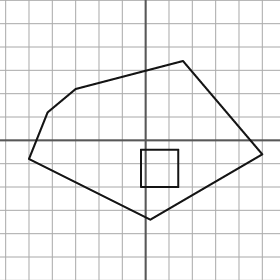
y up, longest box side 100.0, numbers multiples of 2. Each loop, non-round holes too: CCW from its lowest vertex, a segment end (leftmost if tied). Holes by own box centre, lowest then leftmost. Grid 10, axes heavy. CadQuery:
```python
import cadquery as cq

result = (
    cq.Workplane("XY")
    .moveTo(2.0, -34.0)
    .lineTo(50.0, -6.0)
    .lineTo(16.0, 34.0)
    .lineTo(-30.0, 22.0)
    .lineTo(-42.0, 12.0)
    .lineTo(-50.0, -8.0)
    .close()
    .moveTo(-2.0, -20.0)
    .lineTo(14.0, -20.0)
    .lineTo(14.0, -4.0)
    .lineTo(-2.0, -4.0)
    .close()
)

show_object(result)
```